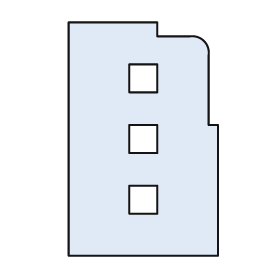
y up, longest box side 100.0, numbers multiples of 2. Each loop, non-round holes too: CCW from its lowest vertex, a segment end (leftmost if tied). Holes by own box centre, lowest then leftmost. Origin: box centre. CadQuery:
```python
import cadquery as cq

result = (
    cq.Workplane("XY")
    .moveTo(-32.0, -50.0)
    .lineTo(32.0, -50.0)
    .lineTo(32.0, 6.0)
    .lineTo(28.0, 6.0)
    .lineTo(28.0, 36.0)
    .threePointArc((26.0, 42.0), (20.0, 44.0))
    .lineTo(6.0, 44.0)
    .lineTo(6.0, 50.0)
    .lineTo(-32.0, 50.0)
    .close()
    .moveTo(-6.0, -32.0)
    .lineTo(6.0, -32.0)
    .lineTo(6.0, -20.0)
    .lineTo(-6.0, -20.0)
    .close()
    .moveTo(-6.0, -6.0)
    .lineTo(6.0, -6.0)
    .lineTo(6.0, 6.0)
    .lineTo(-6.0, 6.0)
    .close()
    .moveTo(-6.0, 20.0)
    .lineTo(6.0, 20.0)
    .lineTo(6.0, 32.0)
    .lineTo(-6.0, 32.0)
    .close()
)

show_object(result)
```